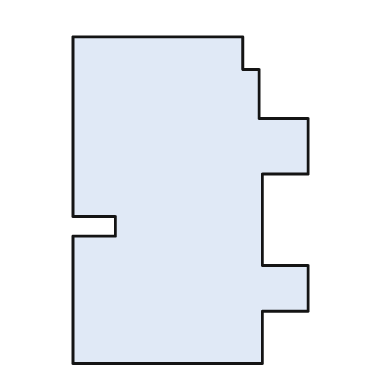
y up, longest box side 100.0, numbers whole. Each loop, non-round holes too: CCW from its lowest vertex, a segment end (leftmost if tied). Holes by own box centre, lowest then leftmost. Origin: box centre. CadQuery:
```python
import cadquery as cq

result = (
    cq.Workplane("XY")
    .moveTo(-36.0, -50.0)
    .lineTo(22.0, -50.0)
    .lineTo(22.0, -34.0)
    .lineTo(36.0, -34.0)
    .lineTo(36.0, -20.0)
    .lineTo(22.0, -20.0)
    .lineTo(22.0, 8.0)
    .lineTo(36.0, 8.0)
    .lineTo(36.0, 25.0)
    .lineTo(21.0, 25.0)
    .lineTo(21.0, 40.0)
    .lineTo(16.0, 40.0)
    .lineTo(16.0, 50.0)
    .lineTo(-36.0, 50.0)
    .lineTo(-36.0, -5.0)
    .lineTo(-23.0, -5.0)
    .lineTo(-23.0, -11.0)
    .lineTo(-36.0, -11.0)
    .close()
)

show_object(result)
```